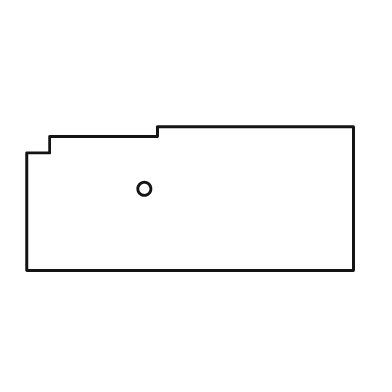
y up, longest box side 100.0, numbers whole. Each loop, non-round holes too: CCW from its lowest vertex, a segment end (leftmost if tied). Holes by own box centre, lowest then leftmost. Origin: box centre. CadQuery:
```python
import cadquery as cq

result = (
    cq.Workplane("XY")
    .moveTo(-50.0, -22.0)
    .lineTo(50.0, -22.0)
    .lineTo(50.0, 22.0)
    .lineTo(-10.0, 22.0)
    .lineTo(-10.0, 19.0)
    .lineTo(-43.0, 19.0)
    .lineTo(-43.0, 14.0)
    .lineTo(-50.0, 14.0)
    .close()
    .moveTo(-14.0, 3.0)
    .circle(2.0)
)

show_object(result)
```